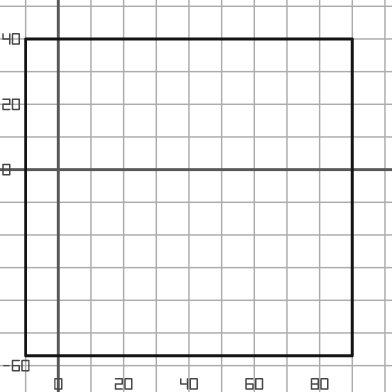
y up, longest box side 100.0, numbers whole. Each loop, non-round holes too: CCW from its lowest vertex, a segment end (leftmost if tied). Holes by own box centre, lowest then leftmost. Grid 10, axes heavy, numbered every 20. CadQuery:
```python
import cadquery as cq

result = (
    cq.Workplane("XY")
    .moveTo(-10.0, -57.0)
    .lineTo(90.0, -57.0)
    .lineTo(90.0, 40.0)
    .lineTo(-10.0, 40.0)
    .close()
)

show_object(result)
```